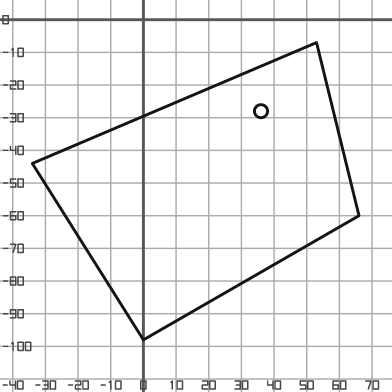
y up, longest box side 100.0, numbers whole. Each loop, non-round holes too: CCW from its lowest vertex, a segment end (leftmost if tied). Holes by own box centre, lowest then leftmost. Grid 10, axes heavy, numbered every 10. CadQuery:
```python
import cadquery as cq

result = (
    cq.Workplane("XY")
    .moveTo(0.0, -98.0)
    .lineTo(66.0, -60.0)
    .lineTo(53.0, -7.0)
    .lineTo(-34.0, -44.0)
    .close()
    .moveTo(36.0, -28.0)
    .circle(2.0)
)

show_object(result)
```